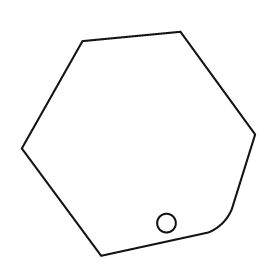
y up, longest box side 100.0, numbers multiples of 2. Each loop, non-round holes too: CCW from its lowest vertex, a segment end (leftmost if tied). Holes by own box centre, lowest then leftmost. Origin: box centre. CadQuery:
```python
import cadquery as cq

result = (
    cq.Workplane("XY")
    .moveTo(-16.0, -48.0)
    .lineTo(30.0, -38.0)
    .threePointArc((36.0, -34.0), (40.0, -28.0))
    .lineTo(50.0, 4.0)
    .lineTo(18.0, 48.0)
    .lineTo(-24.0, 44.0)
    .lineTo(-50.0, -2.0)
    .close()
    .moveTo(12.0, -34.0)
    .circle(4.0)
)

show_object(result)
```